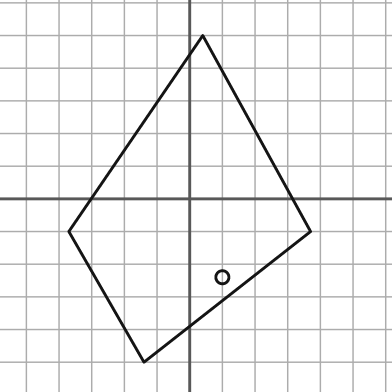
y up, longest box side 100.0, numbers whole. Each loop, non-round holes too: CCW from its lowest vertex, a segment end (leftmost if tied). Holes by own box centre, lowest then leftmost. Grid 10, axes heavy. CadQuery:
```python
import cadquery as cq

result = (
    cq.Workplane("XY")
    .moveTo(-14.0, -50.0)
    .lineTo(37.0, -10.0)
    .lineTo(4.0, 50.0)
    .lineTo(-37.0, -10.0)
    .close()
    .moveTo(10.0, -24.0)
    .circle(2.0)
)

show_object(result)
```